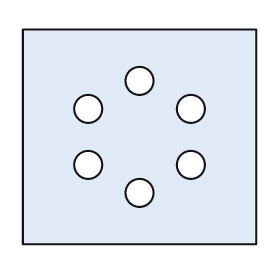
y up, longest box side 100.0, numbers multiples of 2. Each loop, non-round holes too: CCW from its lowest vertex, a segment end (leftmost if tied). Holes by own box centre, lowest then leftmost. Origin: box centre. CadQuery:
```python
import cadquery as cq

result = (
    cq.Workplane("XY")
    .moveTo(-50.0, -46.0)
    .lineTo(50.0, -46.0)
    .lineTo(50.0, 46.0)
    .lineTo(-50.0, 46.0)
    .close()
    .moveTo(0.0, -24.0)
    .circle(6.0)
    .moveTo(-22.0, -12.0)
    .circle(6.0)
    .moveTo(22.0, -12.0)
    .circle(6.0)
    .moveTo(-22.0, 12.0)
    .circle(6.0)
    .moveTo(22.0, 12.0)
    .circle(6.0)
    .moveTo(0.0, 24.0)
    .circle(6.0)
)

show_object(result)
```